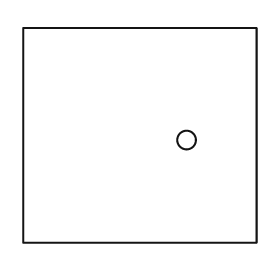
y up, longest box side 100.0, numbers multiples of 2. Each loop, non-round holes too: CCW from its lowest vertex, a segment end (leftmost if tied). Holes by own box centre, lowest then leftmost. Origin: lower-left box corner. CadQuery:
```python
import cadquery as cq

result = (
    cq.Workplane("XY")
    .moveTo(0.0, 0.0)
    .lineTo(100.0, 0.0)
    .lineTo(100.0, 92.0)
    .lineTo(0.0, 92.0)
    .close()
    .moveTo(70.0, 44.0)
    .circle(4.0)
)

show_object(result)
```